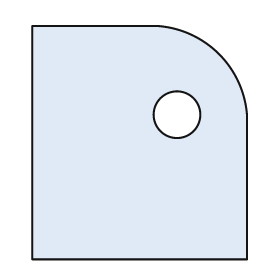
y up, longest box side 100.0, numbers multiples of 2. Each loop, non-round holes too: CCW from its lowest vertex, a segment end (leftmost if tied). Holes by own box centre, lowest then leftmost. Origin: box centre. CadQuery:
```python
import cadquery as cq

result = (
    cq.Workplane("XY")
    .moveTo(-46.0, -50.0)
    .lineTo(46.0, -50.0)
    .lineTo(46.0, 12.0)
    .threePointArc((34.0, 38.0), (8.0, 50.0))
    .lineTo(-46.0, 50.0)
    .close()
    .moveTo(16.0, 12.0)
    .circle(10.0)
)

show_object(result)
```